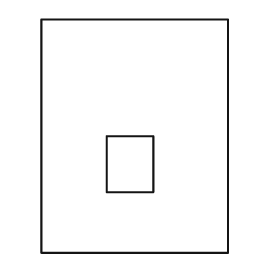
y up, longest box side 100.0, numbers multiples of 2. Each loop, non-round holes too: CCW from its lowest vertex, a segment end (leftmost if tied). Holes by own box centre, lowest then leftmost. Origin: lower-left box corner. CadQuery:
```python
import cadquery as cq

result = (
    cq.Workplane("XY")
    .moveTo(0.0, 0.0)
    .lineTo(80.0, 0.0)
    .lineTo(80.0, 100.0)
    .lineTo(0.0, 100.0)
    .close()
    .moveTo(28.0, 26.0)
    .lineTo(48.0, 26.0)
    .lineTo(48.0, 50.0)
    .lineTo(28.0, 50.0)
    .close()
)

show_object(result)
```